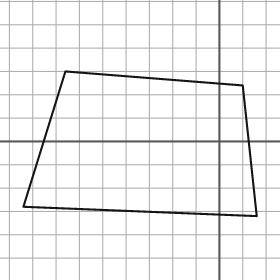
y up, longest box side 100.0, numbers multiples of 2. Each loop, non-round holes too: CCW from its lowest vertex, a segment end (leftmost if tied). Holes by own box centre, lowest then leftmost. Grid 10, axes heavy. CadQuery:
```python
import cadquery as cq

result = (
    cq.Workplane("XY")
    .moveTo(16.0, -32.0)
    .lineTo(10.0, 24.0)
    .lineTo(-66.0, 30.0)
    .lineTo(-84.0, -28.0)
    .close()
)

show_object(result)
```